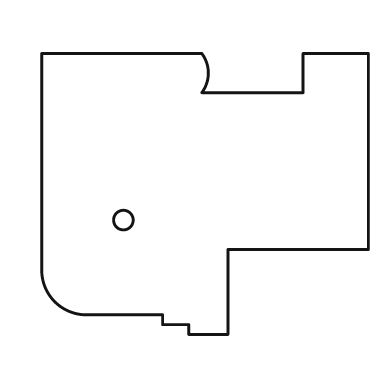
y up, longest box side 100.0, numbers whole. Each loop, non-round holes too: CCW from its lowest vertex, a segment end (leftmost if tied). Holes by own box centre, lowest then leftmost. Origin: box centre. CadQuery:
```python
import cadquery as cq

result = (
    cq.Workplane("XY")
    .moveTo(-5.0, -43.0)
    .lineTo(7.0, -43.0)
    .lineTo(7.0, -17.0)
    .lineTo(50.0, -17.0)
    .lineTo(50.0, 43.0)
    .lineTo(30.0, 43.0)
    .lineTo(30.0, 31.0)
    .lineTo(-1.0, 31.0)
    .threePointArc((1.0, 37.0), (-1.0, 43.0))
    .lineTo(-50.0, 43.0)
    .lineTo(-50.0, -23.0)
    .threePointArc((-46.0, -33.0), (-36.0, -37.0))
    .lineTo(-13.0, -37.0)
    .lineTo(-13.0, -40.0)
    .lineTo(-5.0, -40.0)
    .close()
    .moveTo(-25.0, -8.0)
    .circle(3.0)
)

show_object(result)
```